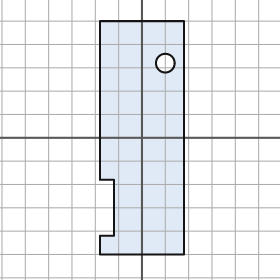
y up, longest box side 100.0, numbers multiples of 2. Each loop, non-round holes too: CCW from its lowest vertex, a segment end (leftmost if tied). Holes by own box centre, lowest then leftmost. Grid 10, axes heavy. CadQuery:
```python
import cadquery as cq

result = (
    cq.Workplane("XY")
    .moveTo(-18.0, -50.0)
    .lineTo(18.0, -50.0)
    .lineTo(18.0, 50.0)
    .lineTo(-18.0, 50.0)
    .lineTo(-18.0, -18.0)
    .lineTo(-12.0, -18.0)
    .lineTo(-12.0, -42.0)
    .lineTo(-18.0, -42.0)
    .close()
    .moveTo(10.0, 32.0)
    .circle(4.0)
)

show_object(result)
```